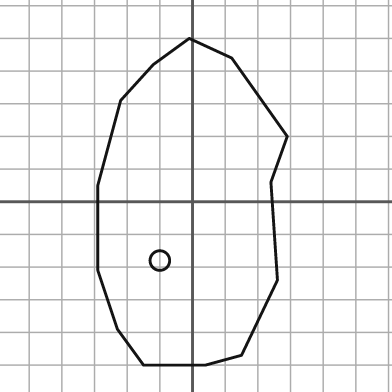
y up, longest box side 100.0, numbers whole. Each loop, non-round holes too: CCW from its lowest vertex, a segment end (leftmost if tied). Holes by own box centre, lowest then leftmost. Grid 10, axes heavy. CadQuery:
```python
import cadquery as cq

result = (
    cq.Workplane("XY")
    .moveTo(-15.0, -50.0)
    .lineTo(4.0, -50.0)
    .lineTo(15.0, -47.0)
    .lineTo(26.0, -24.0)
    .lineTo(24.0, 6.0)
    .lineTo(29.0, 20.0)
    .lineTo(12.0, 44.0)
    .lineTo(-1.0, 50.0)
    .lineTo(-12.0, 42.0)
    .lineTo(-22.0, 31.0)
    .lineTo(-29.0, 5.0)
    .lineTo(-29.0, -21.0)
    .lineTo(-23.0, -39.0)
    .close()
    .moveTo(-10.0, -18.0)
    .circle(3.0)
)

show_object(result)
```